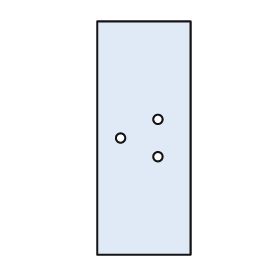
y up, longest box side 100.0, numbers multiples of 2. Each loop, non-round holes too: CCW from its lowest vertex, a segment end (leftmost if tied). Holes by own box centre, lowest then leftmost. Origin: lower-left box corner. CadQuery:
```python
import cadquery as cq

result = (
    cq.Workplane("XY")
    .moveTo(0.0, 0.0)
    .lineTo(40.0, 0.0)
    .lineTo(40.0, 100.0)
    .lineTo(0.0, 100.0)
    .close()
    .moveTo(26.0, 42.0)
    .circle(2.0)
    .moveTo(10.0, 50.0)
    .circle(2.0)
    .moveTo(26.0, 58.0)
    .circle(2.0)
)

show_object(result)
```